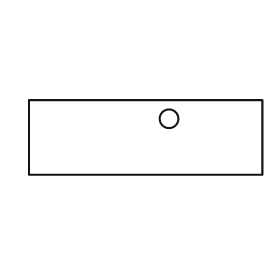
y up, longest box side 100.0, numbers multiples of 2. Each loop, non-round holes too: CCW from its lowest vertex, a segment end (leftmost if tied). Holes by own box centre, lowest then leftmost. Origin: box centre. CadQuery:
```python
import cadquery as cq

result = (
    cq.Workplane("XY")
    .moveTo(-50.0, -16.0)
    .lineTo(50.0, -16.0)
    .lineTo(50.0, 16.0)
    .lineTo(-50.0, 16.0)
    .close()
    .moveTo(10.0, 8.0)
    .circle(4.0)
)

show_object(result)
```